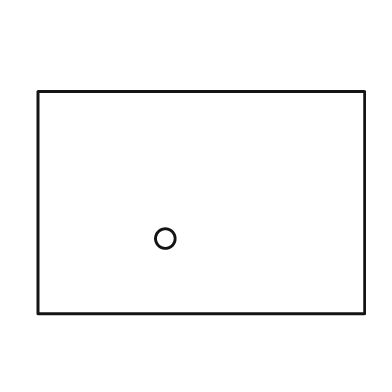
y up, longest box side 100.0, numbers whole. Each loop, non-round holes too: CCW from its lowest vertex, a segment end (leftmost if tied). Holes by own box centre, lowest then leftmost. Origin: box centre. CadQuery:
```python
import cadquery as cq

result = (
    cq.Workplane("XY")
    .moveTo(-50.0, -34.0)
    .lineTo(50.0, -34.0)
    .lineTo(50.0, 34.0)
    .lineTo(-50.0, 34.0)
    .close()
    .moveTo(-11.0, -11.0)
    .circle(3.0)
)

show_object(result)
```